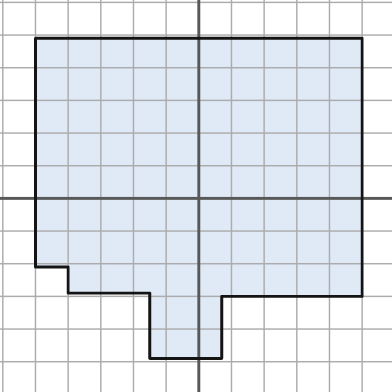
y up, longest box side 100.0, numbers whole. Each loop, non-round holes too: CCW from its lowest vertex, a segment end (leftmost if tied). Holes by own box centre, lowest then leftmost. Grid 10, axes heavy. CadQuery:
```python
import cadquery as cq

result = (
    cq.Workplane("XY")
    .moveTo(-15.0, -49.0)
    .lineTo(7.0, -49.0)
    .lineTo(7.0, -30.0)
    .lineTo(50.0, -30.0)
    .lineTo(50.0, 49.0)
    .lineTo(-50.0, 49.0)
    .lineTo(-50.0, -21.0)
    .lineTo(-40.0, -21.0)
    .lineTo(-40.0, -29.0)
    .lineTo(-15.0, -29.0)
    .close()
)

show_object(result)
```